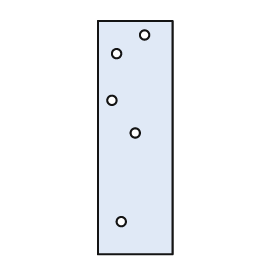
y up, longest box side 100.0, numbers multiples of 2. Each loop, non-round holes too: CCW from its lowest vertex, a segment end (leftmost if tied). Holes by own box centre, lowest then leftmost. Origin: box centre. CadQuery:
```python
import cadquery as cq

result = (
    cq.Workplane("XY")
    .moveTo(-16.0, -50.0)
    .lineTo(16.0, -50.0)
    .lineTo(16.0, 50.0)
    .lineTo(-16.0, 50.0)
    .close()
    .moveTo(-6.0, -36.0)
    .circle(2.0)
    .moveTo(0.0, 2.0)
    .circle(2.0)
    .moveTo(-10.0, 16.0)
    .circle(2.0)
    .moveTo(-8.0, 36.0)
    .circle(2.0)
    .moveTo(4.0, 44.0)
    .circle(2.0)
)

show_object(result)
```